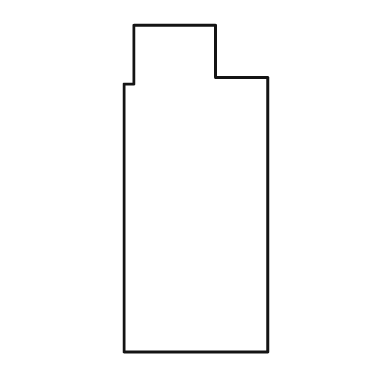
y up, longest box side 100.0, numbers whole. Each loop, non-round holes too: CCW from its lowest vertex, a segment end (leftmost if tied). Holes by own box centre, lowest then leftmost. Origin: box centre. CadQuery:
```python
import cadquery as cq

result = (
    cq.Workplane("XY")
    .moveTo(-22.0, -50.0)
    .lineTo(22.0, -50.0)
    .lineTo(22.0, 34.0)
    .lineTo(6.0, 34.0)
    .lineTo(6.0, 50.0)
    .lineTo(-19.0, 50.0)
    .lineTo(-19.0, 32.0)
    .lineTo(-22.0, 32.0)
    .close()
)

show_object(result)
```